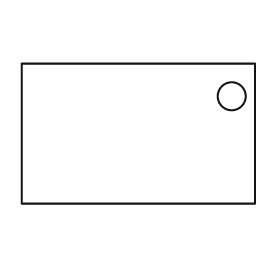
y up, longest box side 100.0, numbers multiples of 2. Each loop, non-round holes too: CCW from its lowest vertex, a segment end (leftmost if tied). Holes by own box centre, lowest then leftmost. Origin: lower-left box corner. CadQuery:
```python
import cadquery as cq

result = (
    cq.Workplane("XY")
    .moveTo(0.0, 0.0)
    .lineTo(100.0, 0.0)
    .lineTo(100.0, 60.0)
    .lineTo(0.0, 60.0)
    .close()
    .moveTo(90.0, 46.0)
    .circle(6.0)
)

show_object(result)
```